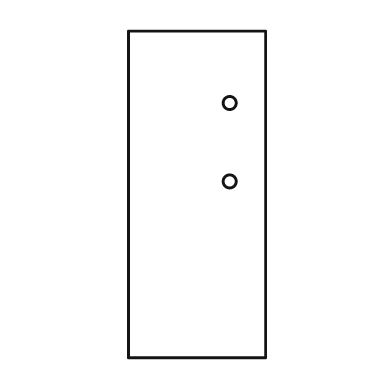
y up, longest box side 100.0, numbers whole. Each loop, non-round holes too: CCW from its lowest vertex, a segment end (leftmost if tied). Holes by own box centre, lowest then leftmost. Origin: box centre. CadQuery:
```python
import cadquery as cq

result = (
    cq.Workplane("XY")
    .moveTo(-21.0, -50.0)
    .lineTo(21.0, -50.0)
    .lineTo(21.0, 50.0)
    .lineTo(-21.0, 50.0)
    .close()
    .moveTo(10.0, 4.0)
    .circle(2.0)
    .moveTo(10.0, 28.0)
    .circle(2.0)
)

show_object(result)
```